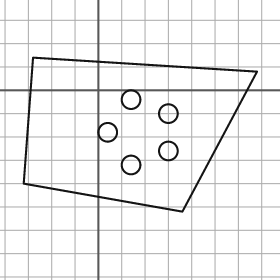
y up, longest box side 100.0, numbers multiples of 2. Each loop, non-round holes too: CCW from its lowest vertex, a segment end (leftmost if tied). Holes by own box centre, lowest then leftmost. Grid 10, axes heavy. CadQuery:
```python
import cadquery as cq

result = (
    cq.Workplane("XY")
    .moveTo(36.0, -52.0)
    .lineTo(68.0, 8.0)
    .lineTo(-28.0, 14.0)
    .lineTo(-32.0, -40.0)
    .close()
    .moveTo(14.0, -32.0)
    .circle(4.0)
    .moveTo(30.0, -26.0)
    .circle(4.0)
    .moveTo(4.0, -18.0)
    .circle(4.0)
    .moveTo(30.0, -10.0)
    .circle(4.0)
    .moveTo(14.0, -4.0)
    .circle(4.0)
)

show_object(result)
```